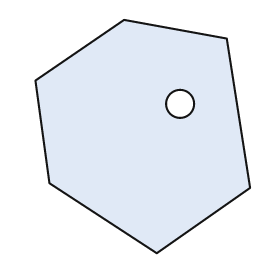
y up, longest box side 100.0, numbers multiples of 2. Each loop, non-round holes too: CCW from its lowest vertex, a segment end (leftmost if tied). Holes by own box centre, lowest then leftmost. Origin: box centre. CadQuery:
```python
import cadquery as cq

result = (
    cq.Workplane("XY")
    .moveTo(6.0, -50.0)
    .lineTo(46.0, -22.0)
    .lineTo(36.0, 42.0)
    .lineTo(-8.0, 50.0)
    .lineTo(-46.0, 24.0)
    .lineTo(-40.0, -20.0)
    .close()
    .moveTo(16.0, 14.0)
    .circle(6.0)
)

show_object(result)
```